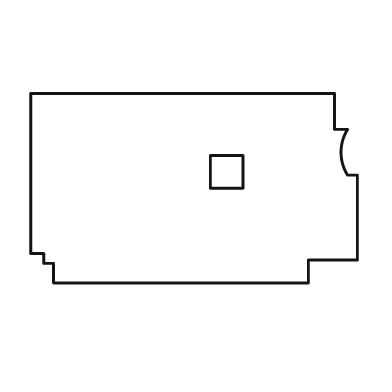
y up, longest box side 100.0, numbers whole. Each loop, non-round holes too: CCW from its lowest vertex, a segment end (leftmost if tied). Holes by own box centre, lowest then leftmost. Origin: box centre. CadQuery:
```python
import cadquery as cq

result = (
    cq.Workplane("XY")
    .moveTo(-43.0, -29.0)
    .lineTo(35.0, -29.0)
    .lineTo(35.0, -22.0)
    .lineTo(50.0, -22.0)
    .lineTo(50.0, 4.0)
    .lineTo(47.0, 4.0)
    .threePointArc((45.0, 11.0), (47.0, 18.0))
    .lineTo(43.0, 18.0)
    .lineTo(43.0, 29.0)
    .lineTo(-50.0, 29.0)
    .lineTo(-50.0, -20.0)
    .lineTo(-46.0, -20.0)
    .lineTo(-46.0, -23.0)
    .lineTo(-43.0, -23.0)
    .close()
    .moveTo(5.0, 0.0)
    .lineTo(15.0, 0.0)
    .lineTo(15.0, 10.0)
    .lineTo(5.0, 10.0)
    .close()
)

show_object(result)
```